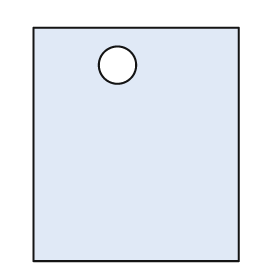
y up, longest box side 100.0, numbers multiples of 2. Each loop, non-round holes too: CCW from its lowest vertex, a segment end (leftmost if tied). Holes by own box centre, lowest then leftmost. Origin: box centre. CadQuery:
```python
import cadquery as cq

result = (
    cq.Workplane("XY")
    .moveTo(-44.0, -50.0)
    .lineTo(44.0, -50.0)
    .lineTo(44.0, 50.0)
    .lineTo(-44.0, 50.0)
    .close()
    .moveTo(-8.0, 34.0)
    .circle(8.0)
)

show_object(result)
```